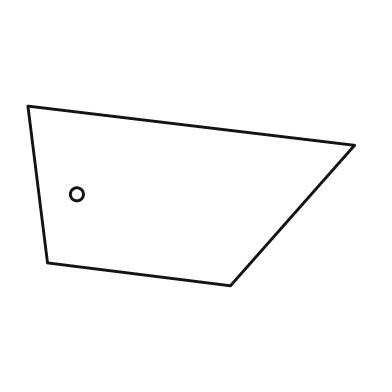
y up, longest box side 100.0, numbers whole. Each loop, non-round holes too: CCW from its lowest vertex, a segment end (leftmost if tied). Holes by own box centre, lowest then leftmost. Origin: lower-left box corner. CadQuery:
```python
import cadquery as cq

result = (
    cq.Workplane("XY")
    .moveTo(62.0, 0.0)
    .lineTo(100.0, 43.0)
    .lineTo(0.0, 55.0)
    .lineTo(6.0, 7.0)
    .close()
    .moveTo(15.0, 28.0)
    .circle(2.0)
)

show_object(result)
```